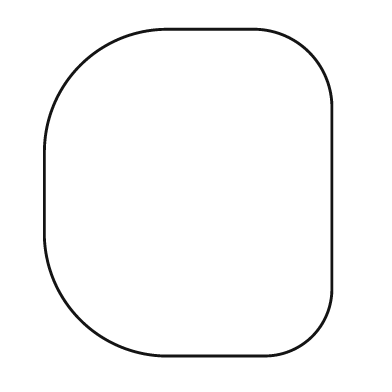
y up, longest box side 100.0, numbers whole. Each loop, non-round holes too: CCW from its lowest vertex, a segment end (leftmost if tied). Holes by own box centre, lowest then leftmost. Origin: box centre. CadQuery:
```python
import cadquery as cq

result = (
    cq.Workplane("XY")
    .moveTo(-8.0, -50.0)
    .lineTo(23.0, -50.0)
    .threePointArc((38.0, -44.0), (44.0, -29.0))
    .lineTo(44.0, 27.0)
    .threePointArc((37.0, 43.0), (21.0, 50.0))
    .lineTo(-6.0, 50.0)
    .threePointArc((-33.0, 39.0), (-44.0, 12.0))
    .lineTo(-44.0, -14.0)
    .threePointArc((-33.0, -39.0), (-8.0, -50.0))
    .close()
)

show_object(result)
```